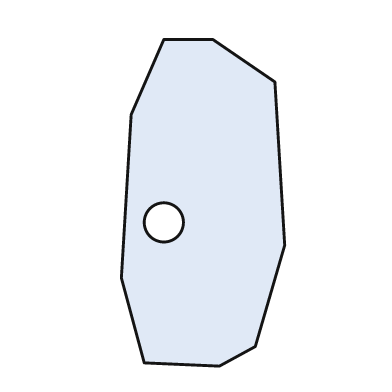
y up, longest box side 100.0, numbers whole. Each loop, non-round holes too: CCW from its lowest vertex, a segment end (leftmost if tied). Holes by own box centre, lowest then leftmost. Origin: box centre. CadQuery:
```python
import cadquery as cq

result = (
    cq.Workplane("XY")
    .moveTo(5.0, -50.0)
    .lineTo(16.0, -44.0)
    .lineTo(25.0, -13.0)
    .lineTo(22.0, 37.0)
    .lineTo(3.0, 50.0)
    .lineTo(-12.0, 50.0)
    .lineTo(-22.0, 27.0)
    .lineTo(-25.0, -23.0)
    .lineTo(-18.0, -49.0)
    .close()
    .moveTo(-12.0, -6.0)
    .circle(6.0)
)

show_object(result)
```